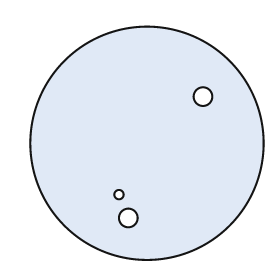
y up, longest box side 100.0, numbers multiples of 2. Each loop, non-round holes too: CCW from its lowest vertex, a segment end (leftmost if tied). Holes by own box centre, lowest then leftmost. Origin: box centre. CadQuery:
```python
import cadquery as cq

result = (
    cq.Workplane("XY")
    .moveTo(0.0, 0.0)
    .circle(50.0)
    .moveTo(-8.0, -32.0)
    .circle(4.0)
    .moveTo(-12.0, -22.0)
    .circle(2.0)
    .moveTo(24.0, 20.0)
    .circle(4.0)
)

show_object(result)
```